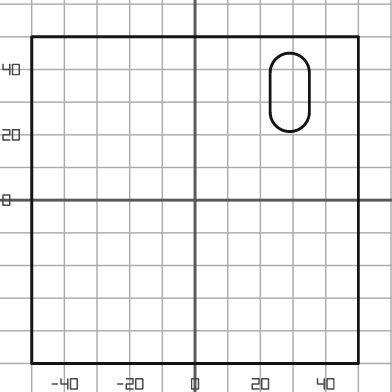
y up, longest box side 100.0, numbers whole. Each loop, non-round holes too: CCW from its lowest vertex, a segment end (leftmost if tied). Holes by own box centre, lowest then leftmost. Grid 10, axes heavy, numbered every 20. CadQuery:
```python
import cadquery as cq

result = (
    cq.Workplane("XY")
    .moveTo(-50.0, -50.0)
    .lineTo(50.0, -50.0)
    .lineTo(50.0, 50.0)
    .lineTo(-50.0, 50.0)
    .close()
    .moveTo(23.0, 27.0)
    .threePointArc((29.0, 21.0), (35.0, 27.0))
    .lineTo(35.0, 39.0)
    .threePointArc((29.0, 45.0), (23.0, 39.0))
    .close()
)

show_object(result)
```